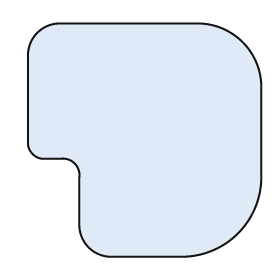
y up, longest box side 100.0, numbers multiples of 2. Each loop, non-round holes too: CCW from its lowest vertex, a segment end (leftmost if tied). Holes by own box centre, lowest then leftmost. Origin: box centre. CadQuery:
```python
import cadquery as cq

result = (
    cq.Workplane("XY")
    .moveTo(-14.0, -50.0)
    .lineTo(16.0, -50.0)
    .threePointArc((40.0, -40.0), (50.0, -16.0))
    .lineTo(50.0, 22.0)
    .threePointArc((42.0, 42.0), (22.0, 50.0))
    .lineTo(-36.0, 50.0)
    .threePointArc((-46.0, 46.0), (-50.0, 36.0))
    .lineTo(-50.0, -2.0)
    .threePointArc((-48.0, -6.0), (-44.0, -8.0))
    .lineTo(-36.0, -8.0)
    .threePointArc((-30.0, -10.0), (-28.0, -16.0))
    .lineTo(-28.0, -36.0)
    .threePointArc((-24.0, -46.0), (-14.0, -50.0))
    .close()
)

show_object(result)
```